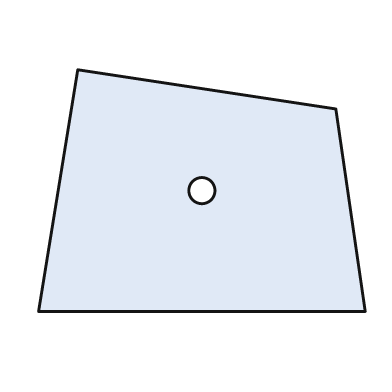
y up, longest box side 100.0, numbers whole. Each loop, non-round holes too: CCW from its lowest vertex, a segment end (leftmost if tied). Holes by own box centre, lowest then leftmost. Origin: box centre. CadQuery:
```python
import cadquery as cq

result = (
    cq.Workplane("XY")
    .moveTo(-50.0, -37.0)
    .lineTo(50.0, -37.0)
    .lineTo(41.0, 25.0)
    .lineTo(-38.0, 37.0)
    .close()
    .moveTo(0.0, 0.0)
    .circle(4.0)
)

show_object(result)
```